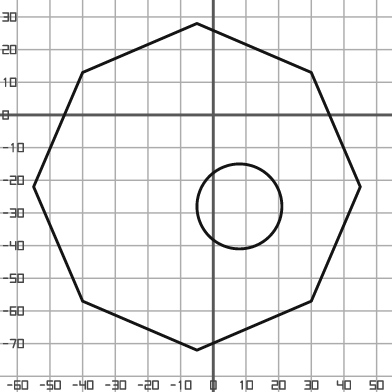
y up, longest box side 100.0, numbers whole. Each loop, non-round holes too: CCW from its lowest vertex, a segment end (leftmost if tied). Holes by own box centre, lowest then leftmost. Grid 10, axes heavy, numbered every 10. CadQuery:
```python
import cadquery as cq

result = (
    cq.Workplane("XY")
    .moveTo(-5.0, -72.0)
    .lineTo(30.0, -57.0)
    .lineTo(45.0, -22.0)
    .lineTo(30.0, 13.0)
    .lineTo(-5.0, 28.0)
    .lineTo(-40.0, 13.0)
    .lineTo(-55.0, -22.0)
    .lineTo(-40.0, -57.0)
    .close()
    .moveTo(8.0, -28.0)
    .circle(13.0)
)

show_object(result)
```